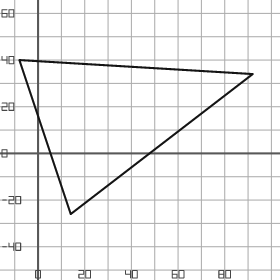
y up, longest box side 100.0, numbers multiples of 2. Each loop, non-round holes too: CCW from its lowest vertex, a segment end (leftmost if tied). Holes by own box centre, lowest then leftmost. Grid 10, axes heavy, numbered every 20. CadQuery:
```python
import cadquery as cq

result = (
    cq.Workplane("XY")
    .moveTo(14.0, -26.0)
    .lineTo(92.0, 34.0)
    .lineTo(-8.0, 40.0)
    .close()
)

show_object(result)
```